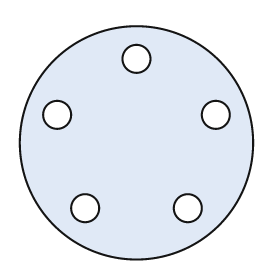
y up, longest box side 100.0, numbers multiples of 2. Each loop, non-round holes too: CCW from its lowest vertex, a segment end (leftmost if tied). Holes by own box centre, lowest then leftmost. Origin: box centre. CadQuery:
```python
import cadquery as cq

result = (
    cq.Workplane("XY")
    .moveTo(0.0, 0.0)
    .circle(50.0)
    .moveTo(-22.0, -28.0)
    .circle(6.0)
    .moveTo(22.0, -28.0)
    .circle(6.0)
    .moveTo(-34.0, 12.0)
    .circle(6.0)
    .moveTo(34.0, 12.0)
    .circle(6.0)
    .moveTo(0.0, 36.0)
    .circle(6.0)
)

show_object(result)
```